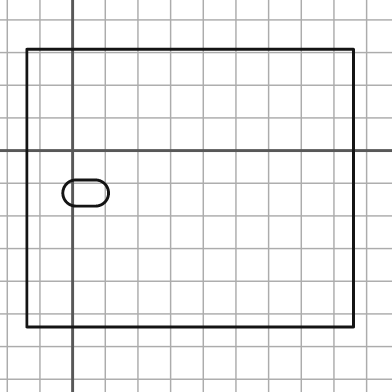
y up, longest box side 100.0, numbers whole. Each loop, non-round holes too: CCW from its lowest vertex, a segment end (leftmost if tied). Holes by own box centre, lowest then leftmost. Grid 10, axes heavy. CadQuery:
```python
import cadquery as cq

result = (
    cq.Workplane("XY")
    .moveTo(-14.0, -54.0)
    .lineTo(86.0, -54.0)
    .lineTo(86.0, 31.0)
    .lineTo(-14.0, 31.0)
    .close()
    .moveTo(1.0, -17.0)
    .lineTo(7.0, -17.0)
    .threePointArc((11.0, -13.0), (7.0, -9.0))
    .lineTo(1.0, -9.0)
    .threePointArc((-3.0, -13.0), (1.0, -17.0))
    .close()
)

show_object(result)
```